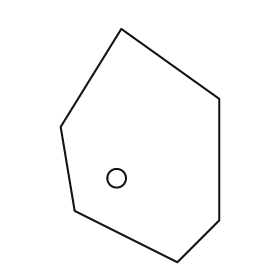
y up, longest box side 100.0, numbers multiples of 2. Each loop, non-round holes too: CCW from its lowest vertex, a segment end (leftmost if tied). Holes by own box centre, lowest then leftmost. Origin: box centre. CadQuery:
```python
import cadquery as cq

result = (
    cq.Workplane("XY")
    .moveTo(16.0, -50.0)
    .lineTo(34.0, -32.0)
    .lineTo(34.0, 20.0)
    .lineTo(-8.0, 50.0)
    .lineTo(-34.0, 8.0)
    .lineTo(-28.0, -28.0)
    .close()
    .moveTo(-10.0, -14.0)
    .circle(4.0)
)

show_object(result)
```